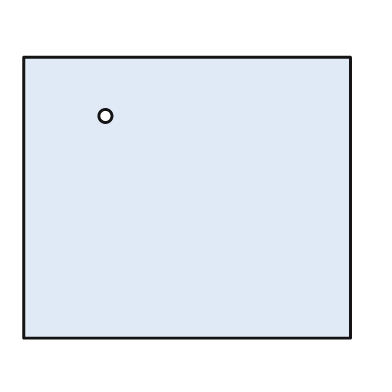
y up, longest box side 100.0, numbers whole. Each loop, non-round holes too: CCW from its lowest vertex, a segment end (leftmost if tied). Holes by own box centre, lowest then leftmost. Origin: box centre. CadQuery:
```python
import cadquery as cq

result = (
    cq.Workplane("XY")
    .moveTo(-50.0, -43.0)
    .lineTo(50.0, -43.0)
    .lineTo(50.0, 43.0)
    .lineTo(-50.0, 43.0)
    .close()
    .moveTo(-25.0, 25.0)
    .circle(2.0)
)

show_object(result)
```